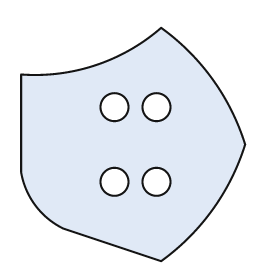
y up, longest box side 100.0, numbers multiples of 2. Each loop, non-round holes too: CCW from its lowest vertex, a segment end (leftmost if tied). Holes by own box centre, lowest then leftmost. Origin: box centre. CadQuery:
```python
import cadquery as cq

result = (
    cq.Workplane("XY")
    .moveTo(12.0, -50.0)
    .threePointArc((34.0, -28.0), (48.0, 0.0))
    .threePointArc((34.0, 28.0), (12.0, 50.0))
    .threePointArc((-16.0, 34.0), (-48.0, 30.0))
    .lineTo(-48.0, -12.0)
    .threePointArc((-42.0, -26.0), (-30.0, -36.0))
    .close()
    .moveTo(-8.0, -16.0)
    .circle(6.0)
    .moveTo(10.0, -16.0)
    .circle(6.0)
    .moveTo(-8.0, 16.0)
    .circle(6.0)
    .moveTo(10.0, 16.0)
    .circle(6.0)
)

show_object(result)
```